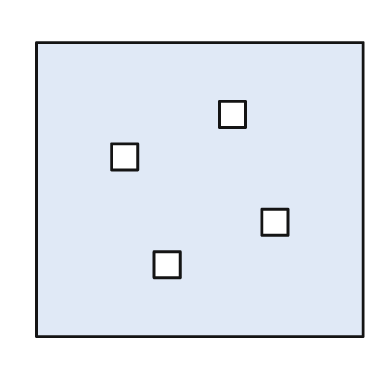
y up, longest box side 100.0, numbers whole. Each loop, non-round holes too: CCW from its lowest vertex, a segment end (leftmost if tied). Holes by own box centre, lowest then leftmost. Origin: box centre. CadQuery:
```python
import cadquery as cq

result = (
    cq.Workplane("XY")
    .moveTo(-50.0, -45.0)
    .lineTo(50.0, -45.0)
    .lineTo(50.0, 45.0)
    .lineTo(-50.0, 45.0)
    .close()
    .moveTo(-14.0, -27.0)
    .lineTo(-6.0, -27.0)
    .lineTo(-6.0, -19.0)
    .lineTo(-14.0, -19.0)
    .close()
    .moveTo(19.0, -14.0)
    .lineTo(27.0, -14.0)
    .lineTo(27.0, -6.0)
    .lineTo(19.0, -6.0)
    .close()
    .moveTo(-27.0, 6.0)
    .lineTo(-19.0, 6.0)
    .lineTo(-19.0, 14.0)
    .lineTo(-27.0, 14.0)
    .close()
    .moveTo(6.0, 19.0)
    .lineTo(14.0, 19.0)
    .lineTo(14.0, 27.0)
    .lineTo(6.0, 27.0)
    .close()
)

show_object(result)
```